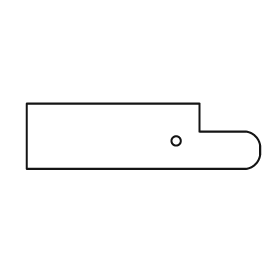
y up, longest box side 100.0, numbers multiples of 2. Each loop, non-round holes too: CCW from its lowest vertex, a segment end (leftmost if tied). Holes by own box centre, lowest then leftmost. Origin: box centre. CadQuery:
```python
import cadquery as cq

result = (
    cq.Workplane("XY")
    .moveTo(-50.0, -14.0)
    .lineTo(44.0, -14.0)
    .threePointArc((48.0, -12.0), (50.0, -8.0))
    .lineTo(50.0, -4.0)
    .threePointArc((48.0, 0.0), (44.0, 2.0))
    .lineTo(24.0, 2.0)
    .lineTo(24.0, 14.0)
    .lineTo(-50.0, 14.0)
    .close()
    .moveTo(14.0, -2.0)
    .circle(2.0)
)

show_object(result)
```